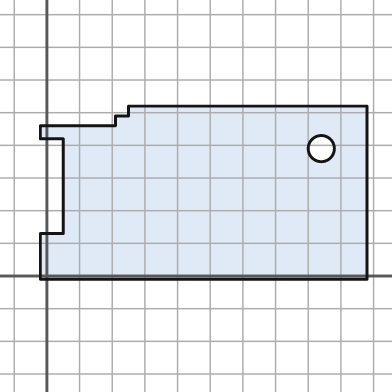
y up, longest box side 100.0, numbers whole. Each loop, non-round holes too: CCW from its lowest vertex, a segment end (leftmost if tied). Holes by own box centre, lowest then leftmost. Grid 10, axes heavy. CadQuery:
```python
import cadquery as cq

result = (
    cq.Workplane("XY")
    .moveTo(-2.0, -1.0)
    .lineTo(98.0, -1.0)
    .lineTo(98.0, 52.0)
    .lineTo(25.0, 52.0)
    .lineTo(25.0, 49.0)
    .lineTo(21.0, 49.0)
    .lineTo(21.0, 46.0)
    .lineTo(-2.0, 46.0)
    .lineTo(-2.0, 42.0)
    .lineTo(5.0, 42.0)
    .lineTo(5.0, 13.0)
    .lineTo(-2.0, 13.0)
    .close()
    .moveTo(84.0, 39.0)
    .circle(4.0)
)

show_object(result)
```